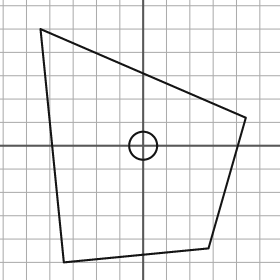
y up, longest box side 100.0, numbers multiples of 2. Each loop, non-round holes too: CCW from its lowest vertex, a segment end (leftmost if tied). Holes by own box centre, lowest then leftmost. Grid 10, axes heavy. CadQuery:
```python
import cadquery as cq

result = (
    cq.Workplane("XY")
    .moveTo(-34.0, -50.0)
    .lineTo(28.0, -44.0)
    .lineTo(44.0, 12.0)
    .lineTo(-44.0, 50.0)
    .close()
    .moveTo(0.0, 0.0)
    .circle(6.0)
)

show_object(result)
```